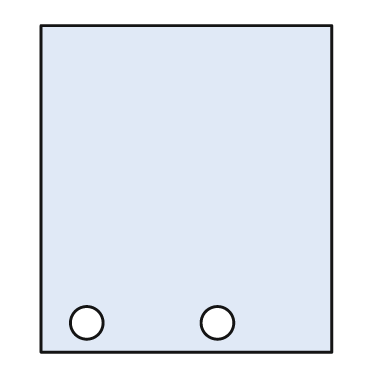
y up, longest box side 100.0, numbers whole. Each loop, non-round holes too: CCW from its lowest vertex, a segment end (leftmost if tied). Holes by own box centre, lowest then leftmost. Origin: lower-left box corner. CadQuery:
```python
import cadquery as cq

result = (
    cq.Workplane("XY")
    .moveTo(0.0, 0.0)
    .lineTo(89.0, 0.0)
    .lineTo(89.0, 100.0)
    .lineTo(0.0, 100.0)
    .close()
    .moveTo(14.0, 9.0)
    .circle(5.0)
    .moveTo(54.0, 9.0)
    .circle(5.0)
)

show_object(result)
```